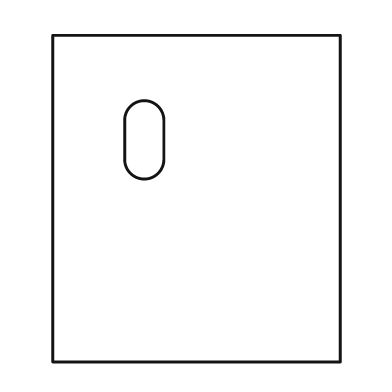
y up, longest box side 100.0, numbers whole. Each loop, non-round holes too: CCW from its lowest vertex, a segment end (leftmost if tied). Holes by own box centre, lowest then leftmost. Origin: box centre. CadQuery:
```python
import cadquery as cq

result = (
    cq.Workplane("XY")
    .moveTo(-44.0, -50.0)
    .lineTo(44.0, -50.0)
    .lineTo(44.0, 50.0)
    .lineTo(-44.0, 50.0)
    .close()
    .moveTo(-22.0, 12.0)
    .threePointArc((-16.0, 6.0), (-10.0, 12.0))
    .lineTo(-10.0, 24.0)
    .threePointArc((-16.0, 30.0), (-22.0, 24.0))
    .close()
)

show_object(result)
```